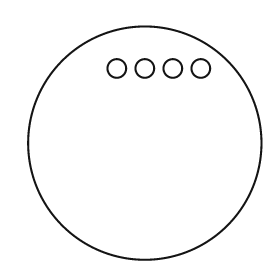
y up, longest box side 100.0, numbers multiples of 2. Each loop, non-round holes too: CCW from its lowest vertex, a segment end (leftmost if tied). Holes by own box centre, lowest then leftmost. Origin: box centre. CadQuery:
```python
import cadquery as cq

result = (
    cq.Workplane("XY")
    .moveTo(0.0, 0.0)
    .circle(50.0)
    .moveTo(-12.0, 32.0)
    .circle(4.0)
    .moveTo(0.0, 32.0)
    .circle(4.0)
    .moveTo(12.0, 32.0)
    .circle(4.0)
    .moveTo(24.0, 32.0)
    .circle(4.0)
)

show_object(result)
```